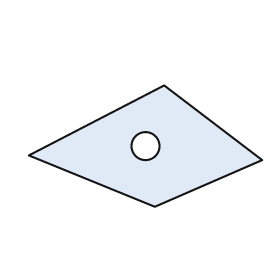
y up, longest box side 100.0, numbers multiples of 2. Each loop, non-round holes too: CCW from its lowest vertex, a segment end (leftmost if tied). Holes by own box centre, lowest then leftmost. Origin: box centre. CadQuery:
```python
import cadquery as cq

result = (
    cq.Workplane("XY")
    .moveTo(4.0, -26.0)
    .lineTo(50.0, -6.0)
    .lineTo(8.0, 26.0)
    .lineTo(-50.0, -4.0)
    .close()
    .moveTo(0.0, 0.0)
    .circle(6.0)
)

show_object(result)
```